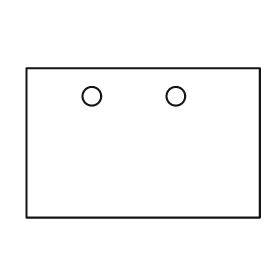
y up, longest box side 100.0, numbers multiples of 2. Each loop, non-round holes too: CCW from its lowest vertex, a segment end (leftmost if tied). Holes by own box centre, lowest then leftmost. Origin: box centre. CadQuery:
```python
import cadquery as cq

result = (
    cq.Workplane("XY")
    .moveTo(-50.0, -32.0)
    .lineTo(50.0, -32.0)
    .lineTo(50.0, 32.0)
    .lineTo(-50.0, 32.0)
    .close()
    .moveTo(-22.0, 20.0)
    .circle(4.0)
    .moveTo(14.0, 20.0)
    .circle(4.0)
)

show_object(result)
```